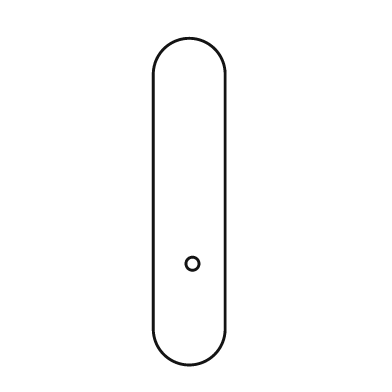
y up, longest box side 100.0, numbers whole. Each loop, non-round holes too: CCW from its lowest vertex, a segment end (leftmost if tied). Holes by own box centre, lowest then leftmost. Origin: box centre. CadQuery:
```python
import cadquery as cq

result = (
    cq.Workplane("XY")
    .moveTo(-11.0, -39.0)
    .threePointArc((0.0, -50.0), (11.0, -39.0))
    .lineTo(11.0, 39.0)
    .threePointArc((0.0, 50.0), (-11.0, 39.0))
    .close()
    .moveTo(1.0, -19.0)
    .circle(2.0)
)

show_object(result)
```